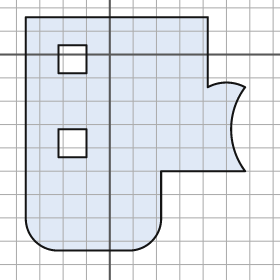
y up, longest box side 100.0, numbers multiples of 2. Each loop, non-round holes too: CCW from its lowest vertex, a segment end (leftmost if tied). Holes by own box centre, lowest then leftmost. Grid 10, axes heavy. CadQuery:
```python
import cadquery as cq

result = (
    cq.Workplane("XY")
    .moveTo(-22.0, -84.0)
    .lineTo(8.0, -84.0)
    .threePointArc((18.0, -80.0), (22.0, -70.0))
    .lineTo(22.0, -50.0)
    .lineTo(58.0, -50.0)
    .threePointArc((52.0, -32.0), (58.0, -14.0))
    .threePointArc((50.0, -12.0), (42.0, -14.0))
    .lineTo(42.0, 16.0)
    .lineTo(-36.0, 16.0)
    .lineTo(-36.0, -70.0)
    .threePointArc((-32.0, -80.0), (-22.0, -84.0))
    .close()
    .moveTo(-22.0, -44.0)
    .lineTo(-10.0, -44.0)
    .lineTo(-10.0, -32.0)
    .lineTo(-22.0, -32.0)
    .close()
    .moveTo(-22.0, -8.0)
    .lineTo(-10.0, -8.0)
    .lineTo(-10.0, 4.0)
    .lineTo(-22.0, 4.0)
    .close()
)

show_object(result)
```